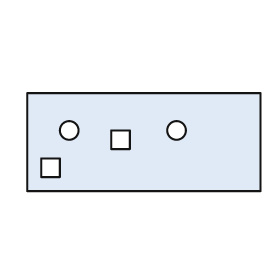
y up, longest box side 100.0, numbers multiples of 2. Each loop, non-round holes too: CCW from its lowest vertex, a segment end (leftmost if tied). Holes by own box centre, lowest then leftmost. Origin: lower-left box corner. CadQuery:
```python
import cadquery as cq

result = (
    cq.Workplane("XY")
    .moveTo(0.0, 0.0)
    .lineTo(100.0, 0.0)
    .lineTo(100.0, 42.0)
    .lineTo(0.0, 42.0)
    .close()
    .moveTo(6.0, 6.0)
    .lineTo(14.0, 6.0)
    .lineTo(14.0, 14.0)
    .lineTo(6.0, 14.0)
    .close()
    .moveTo(36.0, 18.0)
    .lineTo(44.0, 18.0)
    .lineTo(44.0, 26.0)
    .lineTo(36.0, 26.0)
    .close()
    .moveTo(18.0, 26.0)
    .circle(4.0)
    .moveTo(64.0, 26.0)
    .circle(4.0)
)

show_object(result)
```